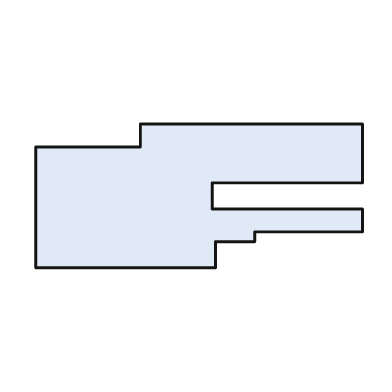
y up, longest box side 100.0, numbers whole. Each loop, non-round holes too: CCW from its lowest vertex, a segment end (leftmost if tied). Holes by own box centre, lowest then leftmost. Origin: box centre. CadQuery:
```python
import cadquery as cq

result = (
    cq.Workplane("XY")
    .moveTo(-50.0, -22.0)
    .lineTo(5.0, -22.0)
    .lineTo(5.0, -14.0)
    .lineTo(17.0, -14.0)
    .lineTo(17.0, -11.0)
    .lineTo(50.0, -11.0)
    .lineTo(50.0, -4.0)
    .lineTo(4.0, -4.0)
    .lineTo(4.0, 4.0)
    .lineTo(50.0, 4.0)
    .lineTo(50.0, 22.0)
    .lineTo(-18.0, 22.0)
    .lineTo(-18.0, 15.0)
    .lineTo(-50.0, 15.0)
    .close()
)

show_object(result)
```